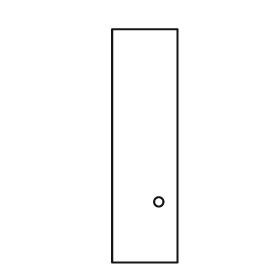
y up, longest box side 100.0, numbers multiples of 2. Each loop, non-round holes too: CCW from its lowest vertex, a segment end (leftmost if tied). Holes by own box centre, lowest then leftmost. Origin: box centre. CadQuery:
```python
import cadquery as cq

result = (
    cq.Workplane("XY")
    .moveTo(-14.0, -50.0)
    .lineTo(14.0, -50.0)
    .lineTo(14.0, 50.0)
    .lineTo(-14.0, 50.0)
    .close()
    .moveTo(6.0, -24.0)
    .circle(2.0)
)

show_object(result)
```